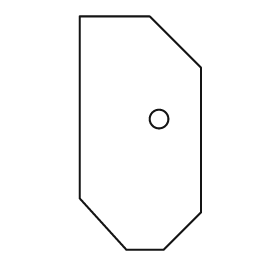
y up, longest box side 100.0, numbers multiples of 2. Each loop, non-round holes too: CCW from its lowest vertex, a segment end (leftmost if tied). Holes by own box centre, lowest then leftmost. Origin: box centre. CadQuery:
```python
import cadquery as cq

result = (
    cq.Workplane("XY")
    .moveTo(-6.0, -50.0)
    .lineTo(10.0, -50.0)
    .lineTo(26.0, -34.0)
    .lineTo(26.0, 28.0)
    .lineTo(4.0, 50.0)
    .lineTo(-26.0, 50.0)
    .lineTo(-26.0, -28.0)
    .close()
    .moveTo(8.0, 6.0)
    .circle(4.0)
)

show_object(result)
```